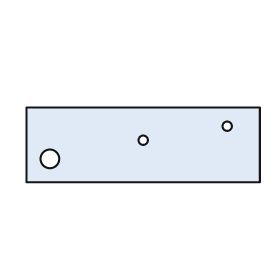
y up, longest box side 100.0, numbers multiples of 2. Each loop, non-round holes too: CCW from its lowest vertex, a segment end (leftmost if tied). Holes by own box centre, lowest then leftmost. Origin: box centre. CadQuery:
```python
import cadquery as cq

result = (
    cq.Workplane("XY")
    .moveTo(-50.0, -16.0)
    .lineTo(50.0, -16.0)
    .lineTo(50.0, 16.0)
    .lineTo(-50.0, 16.0)
    .close()
    .moveTo(-40.0, -6.0)
    .circle(4.0)
    .moveTo(0.0, 2.0)
    .circle(2.0)
    .moveTo(36.0, 8.0)
    .circle(2.0)
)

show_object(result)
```